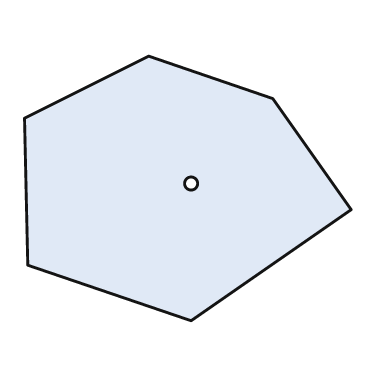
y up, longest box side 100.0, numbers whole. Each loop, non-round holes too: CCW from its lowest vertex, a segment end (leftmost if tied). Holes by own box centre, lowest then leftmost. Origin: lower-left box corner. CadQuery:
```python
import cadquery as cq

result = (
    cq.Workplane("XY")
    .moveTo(51.0, 0.0)
    .lineTo(100.0, 34.0)
    .lineTo(76.0, 68.0)
    .lineTo(38.0, 81.0)
    .lineTo(0.0, 62.0)
    .lineTo(1.0, 17.0)
    .close()
    .moveTo(51.0, 42.0)
    .circle(2.0)
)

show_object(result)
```